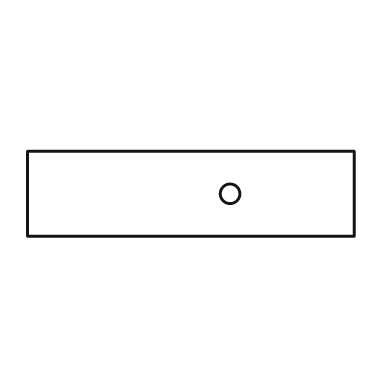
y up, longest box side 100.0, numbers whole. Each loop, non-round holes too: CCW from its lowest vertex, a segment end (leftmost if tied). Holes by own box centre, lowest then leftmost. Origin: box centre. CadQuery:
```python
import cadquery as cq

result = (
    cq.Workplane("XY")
    .moveTo(-50.0, -13.0)
    .lineTo(50.0, -13.0)
    .lineTo(50.0, 13.0)
    .lineTo(-50.0, 13.0)
    .close()
    .moveTo(12.0, 0.0)
    .circle(3.0)
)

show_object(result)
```